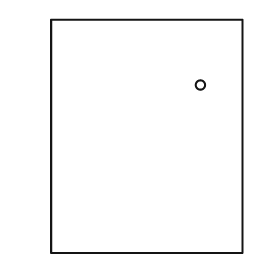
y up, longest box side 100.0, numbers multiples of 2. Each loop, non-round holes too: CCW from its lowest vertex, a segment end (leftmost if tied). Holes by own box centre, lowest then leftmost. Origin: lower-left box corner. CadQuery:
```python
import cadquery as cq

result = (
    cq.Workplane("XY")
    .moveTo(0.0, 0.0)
    .lineTo(82.0, 0.0)
    .lineTo(82.0, 100.0)
    .lineTo(0.0, 100.0)
    .close()
    .moveTo(64.0, 72.0)
    .circle(2.0)
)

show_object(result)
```